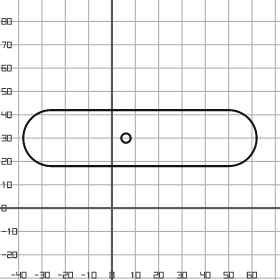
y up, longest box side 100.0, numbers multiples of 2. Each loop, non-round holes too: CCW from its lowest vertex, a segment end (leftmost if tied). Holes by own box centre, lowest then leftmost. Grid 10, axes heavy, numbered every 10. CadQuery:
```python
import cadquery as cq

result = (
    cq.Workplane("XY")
    .moveTo(-26.0, 18.0)
    .lineTo(50.0, 18.0)
    .threePointArc((62.0, 30.0), (50.0, 42.0))
    .lineTo(-26.0, 42.0)
    .threePointArc((-38.0, 30.0), (-26.0, 18.0))
    .close()
    .moveTo(6.0, 30.0)
    .circle(2.0)
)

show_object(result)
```